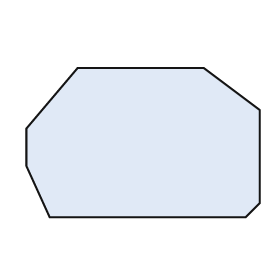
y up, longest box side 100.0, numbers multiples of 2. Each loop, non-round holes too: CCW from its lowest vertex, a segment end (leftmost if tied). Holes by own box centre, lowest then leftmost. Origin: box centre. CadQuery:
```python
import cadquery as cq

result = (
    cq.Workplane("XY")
    .moveTo(-40.0, -32.0)
    .lineTo(44.0, -32.0)
    .lineTo(50.0, -26.0)
    .lineTo(50.0, 14.0)
    .lineTo(26.0, 32.0)
    .lineTo(-28.0, 32.0)
    .lineTo(-50.0, 6.0)
    .lineTo(-50.0, -10.0)
    .close()
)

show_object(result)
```